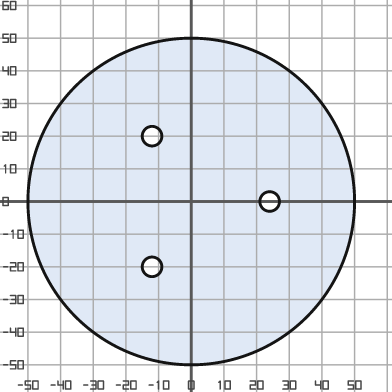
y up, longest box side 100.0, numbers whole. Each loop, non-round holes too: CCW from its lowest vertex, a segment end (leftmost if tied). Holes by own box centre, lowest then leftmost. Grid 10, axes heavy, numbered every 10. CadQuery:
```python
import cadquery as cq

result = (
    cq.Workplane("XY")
    .moveTo(0.0, 0.0)
    .circle(50.0)
    .moveTo(-12.0, -20.0)
    .circle(3.0)
    .moveTo(24.0, 0.0)
    .circle(3.0)
    .moveTo(-12.0, 20.0)
    .circle(3.0)
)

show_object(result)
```